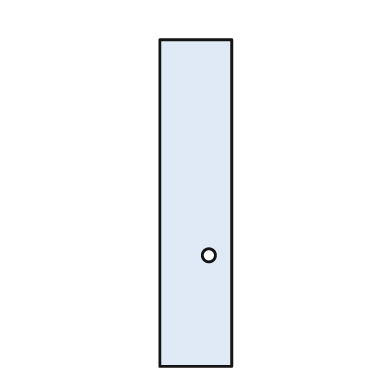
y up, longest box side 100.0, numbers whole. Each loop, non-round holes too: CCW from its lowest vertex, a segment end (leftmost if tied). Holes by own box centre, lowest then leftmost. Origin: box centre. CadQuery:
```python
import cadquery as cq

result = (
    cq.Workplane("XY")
    .moveTo(-11.0, -50.0)
    .lineTo(11.0, -50.0)
    .lineTo(11.0, 50.0)
    .lineTo(-11.0, 50.0)
    .close()
    .moveTo(4.0, -16.0)
    .circle(2.0)
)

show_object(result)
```